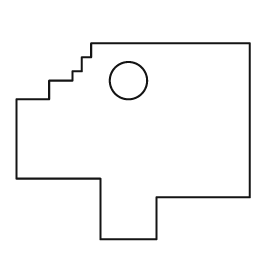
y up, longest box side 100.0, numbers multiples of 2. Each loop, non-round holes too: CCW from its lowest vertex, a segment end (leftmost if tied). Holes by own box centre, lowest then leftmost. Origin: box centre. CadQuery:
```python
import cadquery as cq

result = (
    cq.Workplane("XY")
    .moveTo(-14.0, -42.0)
    .lineTo(10.0, -42.0)
    .lineTo(10.0, -24.0)
    .lineTo(50.0, -24.0)
    .lineTo(50.0, 42.0)
    .lineTo(-18.0, 42.0)
    .lineTo(-18.0, 36.0)
    .lineTo(-22.0, 36.0)
    .lineTo(-22.0, 30.0)
    .lineTo(-26.0, 30.0)
    .lineTo(-26.0, 26.0)
    .lineTo(-36.0, 26.0)
    .lineTo(-36.0, 18.0)
    .lineTo(-50.0, 18.0)
    .lineTo(-50.0, -16.0)
    .lineTo(-14.0, -16.0)
    .close()
    .moveTo(-2.0, 26.0)
    .circle(8.0)
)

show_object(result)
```